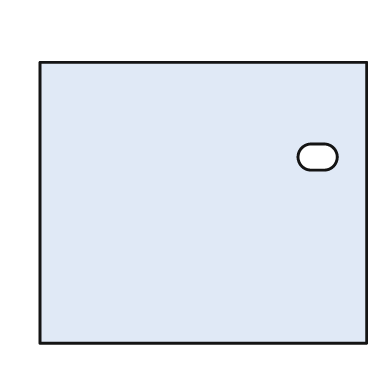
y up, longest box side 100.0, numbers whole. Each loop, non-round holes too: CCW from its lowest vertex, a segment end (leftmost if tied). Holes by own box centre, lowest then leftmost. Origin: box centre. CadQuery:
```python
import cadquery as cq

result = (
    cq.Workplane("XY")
    .moveTo(-50.0, -43.0)
    .lineTo(50.0, -43.0)
    .lineTo(50.0, 43.0)
    .lineTo(-50.0, 43.0)
    .close()
    .moveTo(33.0, 10.0)
    .lineTo(37.0, 10.0)
    .threePointArc((41.0, 14.0), (37.0, 18.0))
    .lineTo(33.0, 18.0)
    .threePointArc((29.0, 14.0), (33.0, 10.0))
    .close()
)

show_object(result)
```